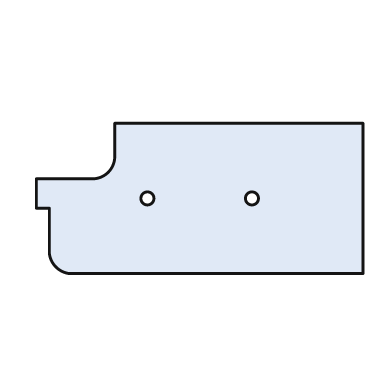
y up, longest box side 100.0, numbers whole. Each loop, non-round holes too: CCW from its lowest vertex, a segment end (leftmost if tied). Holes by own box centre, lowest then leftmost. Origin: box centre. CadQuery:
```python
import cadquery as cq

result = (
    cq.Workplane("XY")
    .moveTo(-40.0, -23.0)
    .lineTo(50.0, -23.0)
    .lineTo(50.0, 23.0)
    .lineTo(-26.0, 23.0)
    .lineTo(-26.0, 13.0)
    .threePointArc((-28.0, 8.0), (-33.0, 6.0))
    .lineTo(-50.0, 6.0)
    .lineTo(-50.0, -3.0)
    .lineTo(-46.0, -3.0)
    .lineTo(-46.0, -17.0)
    .threePointArc((-44.0, -21.0), (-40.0, -23.0))
    .close()
    .moveTo(-16.0, 0.0)
    .circle(2.0)
    .moveTo(16.0, 0.0)
    .circle(2.0)
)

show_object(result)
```